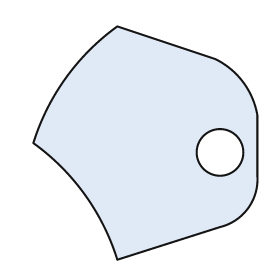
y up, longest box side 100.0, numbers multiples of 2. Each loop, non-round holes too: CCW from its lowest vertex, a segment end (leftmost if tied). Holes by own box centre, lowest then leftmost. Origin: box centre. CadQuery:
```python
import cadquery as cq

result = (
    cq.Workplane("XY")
    .moveTo(-12.0, -50.0)
    .lineTo(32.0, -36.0)
    .threePointArc((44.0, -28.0), (48.0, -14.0))
    .lineTo(48.0, 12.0)
    .threePointArc((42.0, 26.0), (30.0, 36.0))
    .lineTo(-12.0, 50.0)
    .threePointArc((-34.0, 28.0), (-48.0, 0.0))
    .threePointArc((-26.0, -22.0), (-12.0, -50.0))
    .close()
    .moveTo(32.0, -4.0)
    .circle(10.0)
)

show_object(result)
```